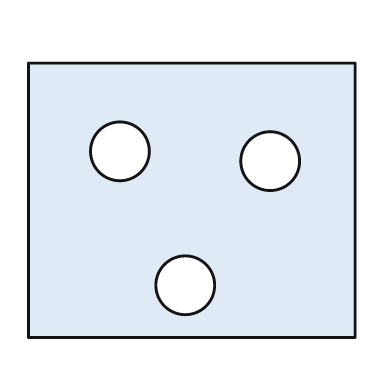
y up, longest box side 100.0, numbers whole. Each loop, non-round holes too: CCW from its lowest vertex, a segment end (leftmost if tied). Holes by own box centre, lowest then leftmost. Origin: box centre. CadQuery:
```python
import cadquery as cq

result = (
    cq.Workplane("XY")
    .moveTo(-50.0, -42.0)
    .lineTo(50.0, -42.0)
    .lineTo(50.0, 42.0)
    .lineTo(-50.0, 42.0)
    .close()
    .moveTo(-2.0, -26.0)
    .circle(9.0)
    .moveTo(24.0, 12.0)
    .circle(9.0)
    .moveTo(-22.0, 15.0)
    .circle(9.0)
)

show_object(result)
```